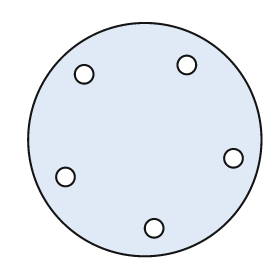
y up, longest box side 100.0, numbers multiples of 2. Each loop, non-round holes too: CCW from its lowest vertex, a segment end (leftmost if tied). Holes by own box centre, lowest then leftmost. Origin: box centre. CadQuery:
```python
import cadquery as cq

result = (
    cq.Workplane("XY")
    .moveTo(0.0, 0.0)
    .circle(50.0)
    .moveTo(4.0, -38.0)
    .circle(4.0)
    .moveTo(-34.0, -16.0)
    .circle(4.0)
    .moveTo(38.0, -8.0)
    .circle(4.0)
    .moveTo(-26.0, 28.0)
    .circle(4.0)
    .moveTo(18.0, 32.0)
    .circle(4.0)
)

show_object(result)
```